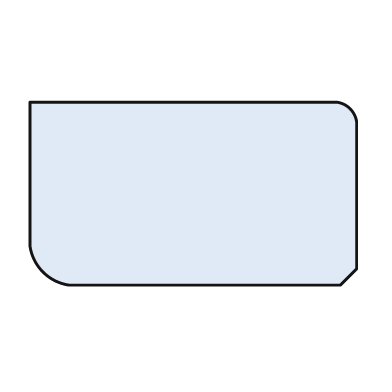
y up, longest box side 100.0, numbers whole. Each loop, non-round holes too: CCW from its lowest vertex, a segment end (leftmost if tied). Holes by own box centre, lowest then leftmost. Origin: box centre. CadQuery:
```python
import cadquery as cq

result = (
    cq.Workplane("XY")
    .moveTo(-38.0, -28.0)
    .lineTo(45.0, -28.0)
    .lineTo(50.0, -23.0)
    .lineTo(50.0, 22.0)
    .threePointArc((48.0, 26.0), (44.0, 28.0))
    .lineTo(-50.0, 28.0)
    .lineTo(-50.0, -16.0)
    .threePointArc((-46.0, -24.0), (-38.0, -28.0))
    .close()
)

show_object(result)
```